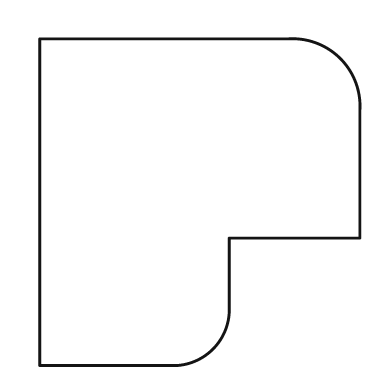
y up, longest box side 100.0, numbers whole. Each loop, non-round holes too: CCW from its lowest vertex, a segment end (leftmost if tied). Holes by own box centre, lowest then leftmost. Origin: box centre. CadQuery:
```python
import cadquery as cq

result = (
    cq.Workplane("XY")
    .moveTo(-49.0, -50.0)
    .lineTo(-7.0, -50.0)
    .threePointArc((4.0, -45.0), (9.0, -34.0))
    .lineTo(9.0, -11.0)
    .lineTo(49.0, -11.0)
    .lineTo(49.0, 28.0)
    .threePointArc((43.0, 44.0), (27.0, 50.0))
    .lineTo(-49.0, 50.0)
    .close()
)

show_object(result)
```